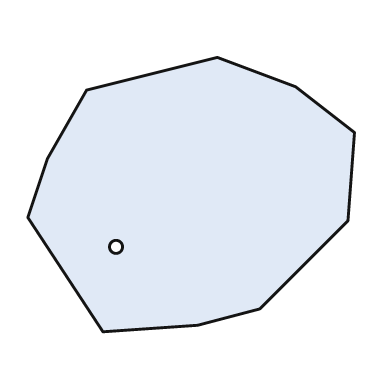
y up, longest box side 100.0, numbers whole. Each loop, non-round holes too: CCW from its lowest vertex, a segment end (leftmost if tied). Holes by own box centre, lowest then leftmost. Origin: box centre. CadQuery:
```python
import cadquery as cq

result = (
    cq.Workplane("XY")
    .moveTo(-27.0, -42.0)
    .lineTo(2.0, -40.0)
    .lineTo(21.0, -35.0)
    .lineTo(48.0, -8.0)
    .lineTo(50.0, 19.0)
    .lineTo(32.0, 33.0)
    .lineTo(8.0, 42.0)
    .lineTo(-32.0, 32.0)
    .lineTo(-44.0, 11.0)
    .lineTo(-50.0, -7.0)
    .close()
    .moveTo(-23.0, -16.0)
    .circle(2.0)
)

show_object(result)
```